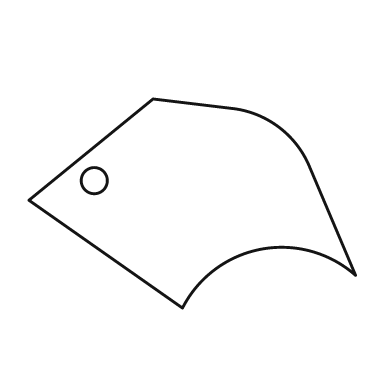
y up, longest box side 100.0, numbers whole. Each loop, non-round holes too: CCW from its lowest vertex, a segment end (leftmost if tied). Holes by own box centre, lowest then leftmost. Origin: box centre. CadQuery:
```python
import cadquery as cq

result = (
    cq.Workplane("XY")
    .moveTo(-3.0, -32.0)
    .threePointArc((21.0, -14.0), (50.0, -22.0))
    .lineTo(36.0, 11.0)
    .threePointArc((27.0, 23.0), (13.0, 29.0))
    .lineTo(-12.0, 32.0)
    .lineTo(-50.0, 1.0)
    .close()
    .moveTo(-30.0, 7.0)
    .circle(4.0)
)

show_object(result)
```